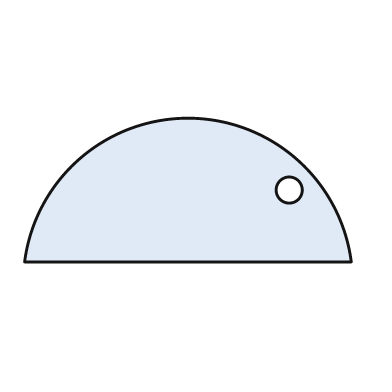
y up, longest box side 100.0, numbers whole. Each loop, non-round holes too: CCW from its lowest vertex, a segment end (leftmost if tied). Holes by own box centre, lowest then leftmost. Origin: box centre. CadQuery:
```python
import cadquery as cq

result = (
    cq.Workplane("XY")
    .moveTo(-50.0, -22.0)
    .lineTo(50.0, -22.0)
    .threePointArc((0.0, 22.0), (-50.0, -22.0))
    .close()
    .moveTo(31.0, 0.0)
    .circle(4.0)
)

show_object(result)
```